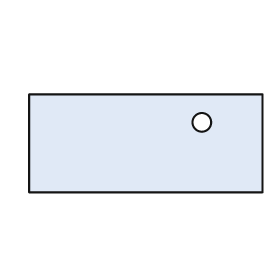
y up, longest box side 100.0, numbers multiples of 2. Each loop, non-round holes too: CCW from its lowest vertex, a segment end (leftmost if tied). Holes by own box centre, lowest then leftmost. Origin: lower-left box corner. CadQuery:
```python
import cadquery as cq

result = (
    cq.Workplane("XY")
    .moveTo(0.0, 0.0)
    .lineTo(100.0, 0.0)
    .lineTo(100.0, 42.0)
    .lineTo(0.0, 42.0)
    .close()
    .moveTo(74.0, 30.0)
    .circle(4.0)
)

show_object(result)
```